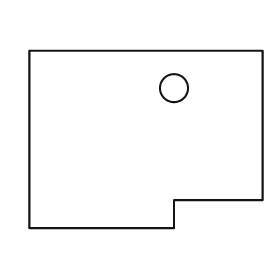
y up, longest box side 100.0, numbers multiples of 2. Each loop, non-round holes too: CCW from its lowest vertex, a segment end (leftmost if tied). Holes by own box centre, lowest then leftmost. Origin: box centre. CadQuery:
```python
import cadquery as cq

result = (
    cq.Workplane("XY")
    .moveTo(-50.0, -38.0)
    .lineTo(12.0, -38.0)
    .lineTo(12.0, -26.0)
    .lineTo(50.0, -26.0)
    .lineTo(50.0, 38.0)
    .lineTo(-50.0, 38.0)
    .close()
    .moveTo(12.0, 22.0)
    .circle(6.0)
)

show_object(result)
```